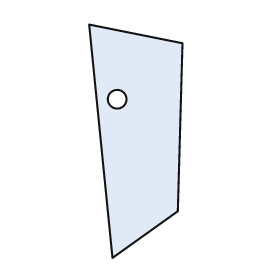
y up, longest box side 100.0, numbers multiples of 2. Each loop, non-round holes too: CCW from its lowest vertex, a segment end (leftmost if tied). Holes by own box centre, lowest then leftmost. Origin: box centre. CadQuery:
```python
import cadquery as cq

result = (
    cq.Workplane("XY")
    .moveTo(-10.0, -50.0)
    .lineTo(18.0, -30.0)
    .lineTo(20.0, 42.0)
    .lineTo(-20.0, 50.0)
    .close()
    .moveTo(-8.0, 18.0)
    .circle(4.0)
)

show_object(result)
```